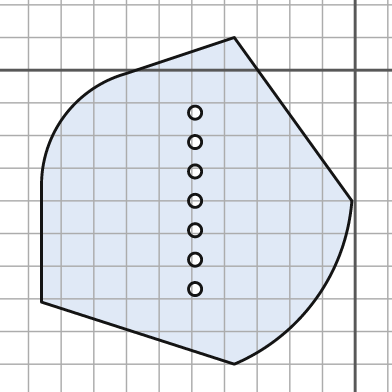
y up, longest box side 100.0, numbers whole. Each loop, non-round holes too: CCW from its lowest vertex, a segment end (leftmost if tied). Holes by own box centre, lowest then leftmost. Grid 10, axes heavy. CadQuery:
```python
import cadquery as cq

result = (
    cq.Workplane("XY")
    .moveTo(-37.0, -90.0)
    .threePointArc((-12.0, -70.0), (-1.0, -40.0))
    .lineTo(-37.0, 10.0)
    .lineTo(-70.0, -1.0)
    .threePointArc((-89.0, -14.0), (-96.0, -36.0))
    .lineTo(-96.0, -71.0)
    .close()
    .moveTo(-49.0, -67.0)
    .circle(2.0)
    .moveTo(-49.0, -58.0)
    .circle(2.0)
    .moveTo(-49.0, -49.0)
    .circle(2.0)
    .moveTo(-49.0, -40.0)
    .circle(2.0)
    .moveTo(-49.0, -31.0)
    .circle(2.0)
    .moveTo(-49.0, -22.0)
    .circle(2.0)
    .moveTo(-49.0, -13.0)
    .circle(2.0)
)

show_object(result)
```